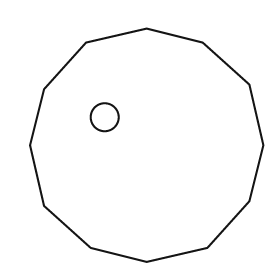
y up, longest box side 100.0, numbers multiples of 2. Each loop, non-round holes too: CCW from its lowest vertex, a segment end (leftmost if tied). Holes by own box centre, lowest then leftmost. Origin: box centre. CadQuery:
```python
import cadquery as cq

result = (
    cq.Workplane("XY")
    .moveTo(0.0, -50.0)
    .lineTo(26.0, -44.0)
    .lineTo(44.0, -24.0)
    .lineTo(50.0, 0.0)
    .lineTo(44.0, 26.0)
    .lineTo(24.0, 44.0)
    .lineTo(0.0, 50.0)
    .lineTo(-26.0, 44.0)
    .lineTo(-44.0, 24.0)
    .lineTo(-50.0, 0.0)
    .lineTo(-44.0, -26.0)
    .lineTo(-24.0, -44.0)
    .close()
    .moveTo(-18.0, 12.0)
    .circle(6.0)
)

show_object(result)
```